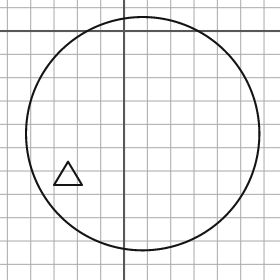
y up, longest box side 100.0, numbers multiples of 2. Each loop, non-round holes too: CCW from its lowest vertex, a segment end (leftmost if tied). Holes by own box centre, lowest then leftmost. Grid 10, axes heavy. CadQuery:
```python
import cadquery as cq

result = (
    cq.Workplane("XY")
    .moveTo(8.0, -44.0)
    .circle(50.0)
    .moveTo(-30.0, -66.0)
    .lineTo(-18.0, -66.0)
    .lineTo(-24.0, -56.0)
    .close()
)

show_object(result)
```